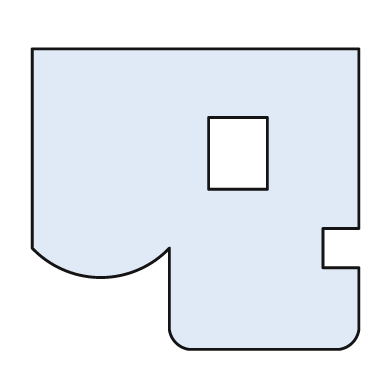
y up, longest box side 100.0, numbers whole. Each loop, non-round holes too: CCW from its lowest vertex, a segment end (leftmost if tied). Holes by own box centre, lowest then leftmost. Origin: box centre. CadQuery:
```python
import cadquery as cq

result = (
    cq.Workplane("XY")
    .moveTo(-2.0, -46.0)
    .lineTo(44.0, -46.0)
    .threePointArc((48.0, -44.0), (50.0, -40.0))
    .lineTo(50.0, -21.0)
    .lineTo(39.0, -21.0)
    .lineTo(39.0, -9.0)
    .lineTo(50.0, -9.0)
    .lineTo(50.0, 46.0)
    .lineTo(-50.0, 46.0)
    .lineTo(-50.0, -15.0)
    .threePointArc((-29.0, -24.0), (-8.0, -15.0))
    .lineTo(-8.0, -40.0)
    .threePointArc((-6.0, -44.0), (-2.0, -46.0))
    .close()
    .moveTo(4.0, 3.0)
    .lineTo(22.0, 3.0)
    .lineTo(22.0, 25.0)
    .lineTo(4.0, 25.0)
    .close()
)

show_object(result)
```